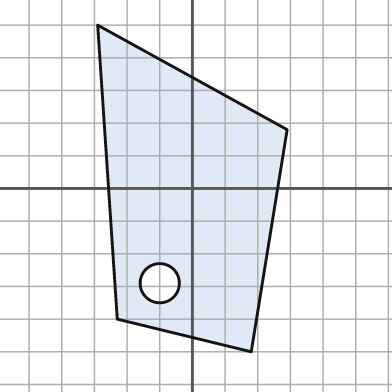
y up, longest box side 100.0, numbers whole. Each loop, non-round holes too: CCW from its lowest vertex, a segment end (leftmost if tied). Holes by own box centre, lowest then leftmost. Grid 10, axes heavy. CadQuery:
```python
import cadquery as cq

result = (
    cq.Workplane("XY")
    .moveTo(18.0, -50.0)
    .lineTo(29.0, 18.0)
    .lineTo(-29.0, 50.0)
    .lineTo(-23.0, -40.0)
    .close()
    .moveTo(-10.0, -29.0)
    .circle(6.0)
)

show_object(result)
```